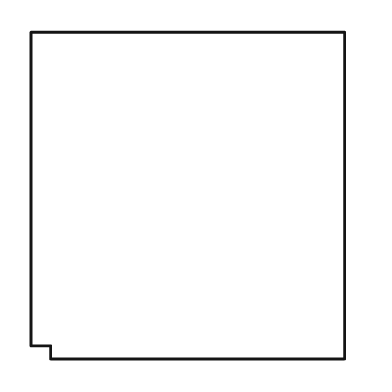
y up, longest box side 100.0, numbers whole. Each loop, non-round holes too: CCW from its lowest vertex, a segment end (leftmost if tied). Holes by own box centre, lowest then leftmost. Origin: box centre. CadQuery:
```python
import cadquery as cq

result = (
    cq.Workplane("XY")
    .moveTo(-42.0, -50.0)
    .lineTo(48.0, -50.0)
    .lineTo(48.0, 50.0)
    .lineTo(-48.0, 50.0)
    .lineTo(-48.0, -46.0)
    .lineTo(-42.0, -46.0)
    .close()
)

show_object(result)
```